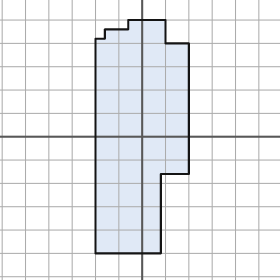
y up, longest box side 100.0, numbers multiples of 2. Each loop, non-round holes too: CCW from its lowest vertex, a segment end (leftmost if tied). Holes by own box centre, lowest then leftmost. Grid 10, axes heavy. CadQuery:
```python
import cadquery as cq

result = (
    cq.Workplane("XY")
    .moveTo(-20.0, -50.0)
    .lineTo(8.0, -50.0)
    .lineTo(8.0, -16.0)
    .lineTo(20.0, -16.0)
    .lineTo(20.0, 40.0)
    .lineTo(10.0, 40.0)
    .lineTo(10.0, 50.0)
    .lineTo(-6.0, 50.0)
    .lineTo(-6.0, 46.0)
    .lineTo(-16.0, 46.0)
    .lineTo(-16.0, 42.0)
    .lineTo(-20.0, 42.0)
    .close()
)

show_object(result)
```